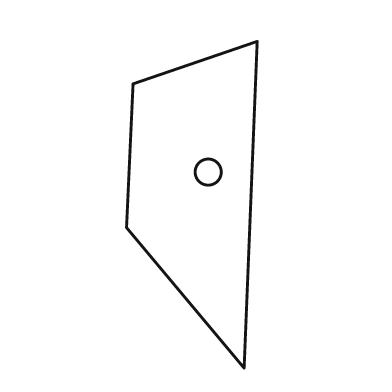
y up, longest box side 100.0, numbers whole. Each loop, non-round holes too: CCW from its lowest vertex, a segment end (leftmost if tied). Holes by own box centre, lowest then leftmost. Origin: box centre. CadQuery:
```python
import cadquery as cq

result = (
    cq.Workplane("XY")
    .moveTo(16.0, -50.0)
    .lineTo(20.0, 50.0)
    .lineTo(-18.0, 37.0)
    .lineTo(-20.0, -7.0)
    .close()
    .moveTo(5.0, 10.0)
    .circle(4.0)
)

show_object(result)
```